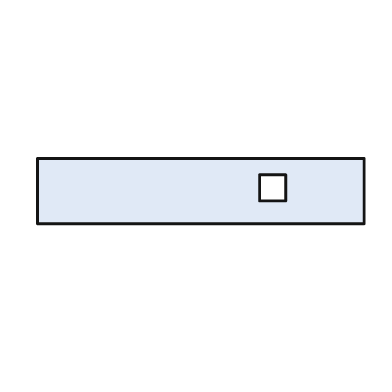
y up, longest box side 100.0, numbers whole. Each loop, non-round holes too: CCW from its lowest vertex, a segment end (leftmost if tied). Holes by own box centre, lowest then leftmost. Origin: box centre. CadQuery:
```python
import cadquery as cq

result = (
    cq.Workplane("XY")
    .moveTo(-50.0, -10.0)
    .lineTo(50.0, -10.0)
    .lineTo(50.0, 10.0)
    .lineTo(-50.0, 10.0)
    .close()
    .moveTo(18.0, -3.0)
    .lineTo(26.0, -3.0)
    .lineTo(26.0, 5.0)
    .lineTo(18.0, 5.0)
    .close()
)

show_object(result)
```